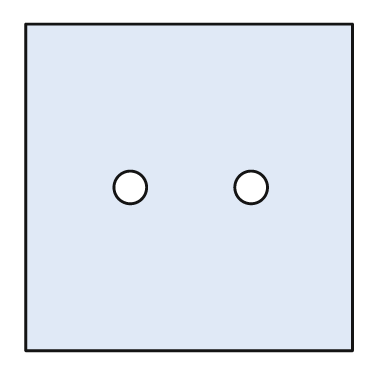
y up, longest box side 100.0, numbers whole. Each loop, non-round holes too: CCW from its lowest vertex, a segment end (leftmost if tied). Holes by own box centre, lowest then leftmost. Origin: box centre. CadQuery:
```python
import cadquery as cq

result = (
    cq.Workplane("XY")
    .moveTo(-50.0, -50.0)
    .lineTo(50.0, -50.0)
    .lineTo(50.0, 50.0)
    .lineTo(-50.0, 50.0)
    .close()
    .moveTo(-18.0, 0.0)
    .circle(5.0)
    .moveTo(19.0, 0.0)
    .circle(5.0)
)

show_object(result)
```